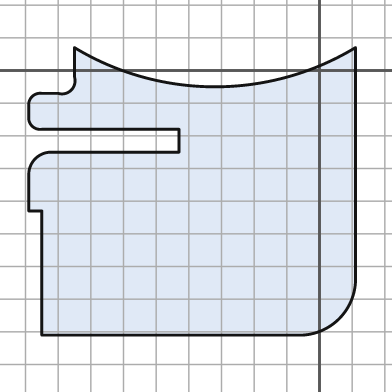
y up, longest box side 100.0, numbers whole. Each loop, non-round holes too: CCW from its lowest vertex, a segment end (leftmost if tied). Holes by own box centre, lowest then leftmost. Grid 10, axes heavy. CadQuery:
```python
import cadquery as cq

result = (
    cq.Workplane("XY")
    .moveTo(-85.0, -81.0)
    .lineTo(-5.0, -81.0)
    .threePointArc((6.0, -76.0), (11.0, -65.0))
    .lineTo(11.0, 7.0)
    .threePointArc((-32.0, -5.0), (-75.0, 7.0))
    .lineTo(-75.0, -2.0)
    .threePointArc((-76.0, -6.0), (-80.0, -7.0))
    .lineTo(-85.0, -7.0)
    .threePointArc((-88.0, -8.0), (-89.0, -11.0))
    .lineTo(-89.0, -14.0)
    .threePointArc((-88.0, -17.0), (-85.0, -18.0))
    .lineTo(-43.0, -18.0)
    .lineTo(-43.0, -25.0)
    .lineTo(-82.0, -25.0)
    .threePointArc((-87.0, -27.0), (-89.0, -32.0))
    .lineTo(-89.0, -43.0)
    .lineTo(-85.0, -43.0)
    .close()
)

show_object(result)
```